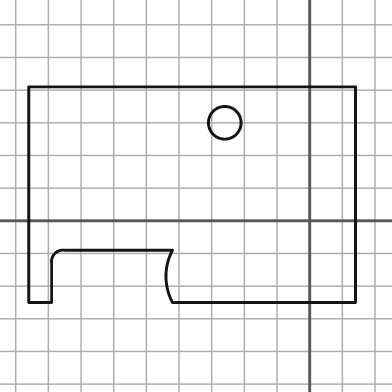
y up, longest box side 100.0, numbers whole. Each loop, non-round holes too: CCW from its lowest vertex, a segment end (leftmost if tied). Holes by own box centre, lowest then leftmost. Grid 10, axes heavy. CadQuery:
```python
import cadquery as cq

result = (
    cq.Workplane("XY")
    .moveTo(-86.0, -25.0)
    .lineTo(-79.0, -25.0)
    .lineTo(-79.0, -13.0)
    .threePointArc((-78.0, -10.0), (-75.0, -9.0))
    .lineTo(-42.0, -9.0)
    .threePointArc((-44.0, -17.0), (-42.0, -25.0))
    .lineTo(14.0, -25.0)
    .lineTo(14.0, 41.0)
    .lineTo(-86.0, 41.0)
    .close()
    .moveTo(-26.0, 30.0)
    .circle(5.0)
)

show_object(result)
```